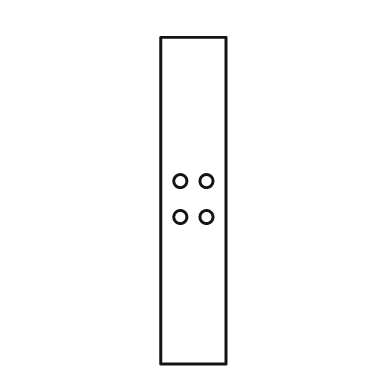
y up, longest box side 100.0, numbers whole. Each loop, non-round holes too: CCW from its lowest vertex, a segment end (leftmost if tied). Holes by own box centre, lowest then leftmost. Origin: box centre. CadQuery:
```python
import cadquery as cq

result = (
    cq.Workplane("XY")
    .moveTo(-10.0, -50.0)
    .lineTo(10.0, -50.0)
    .lineTo(10.0, 50.0)
    .lineTo(-10.0, 50.0)
    .close()
    .moveTo(-4.0, -5.0)
    .circle(2.0)
    .moveTo(4.0, -5.0)
    .circle(2.0)
    .moveTo(-4.0, 6.0)
    .circle(2.0)
    .moveTo(4.0, 6.0)
    .circle(2.0)
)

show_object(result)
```